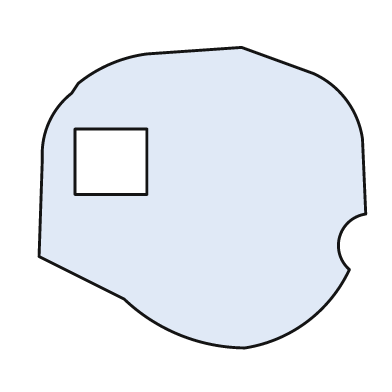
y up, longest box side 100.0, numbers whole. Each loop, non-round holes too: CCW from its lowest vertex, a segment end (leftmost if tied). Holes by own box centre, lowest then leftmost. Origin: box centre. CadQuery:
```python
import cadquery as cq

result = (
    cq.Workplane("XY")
    .moveTo(13.0, -46.0)
    .threePointArc((32.0, -38.0), (45.0, -22.0))
    .threePointArc((42.0, -12.0), (50.0, -5.0))
    .lineTo(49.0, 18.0)
    .threePointArc((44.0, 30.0), (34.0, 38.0))
    .lineTo(12.0, 46.0)
    .lineTo(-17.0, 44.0)
    .threePointArc((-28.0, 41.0), (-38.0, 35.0))
    .lineTo(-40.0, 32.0)
    .threePointArc((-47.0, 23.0), (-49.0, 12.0))
    .lineTo(-50.0, -18.0)
    .lineTo(-24.0, -31.0)
    .threePointArc((-7.0, -42.0), (13.0, -46.0))
    .close()
    .moveTo(-39.0, 1.0)
    .lineTo(-17.0, 1.0)
    .lineTo(-17.0, 21.0)
    .lineTo(-39.0, 21.0)
    .close()
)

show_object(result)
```